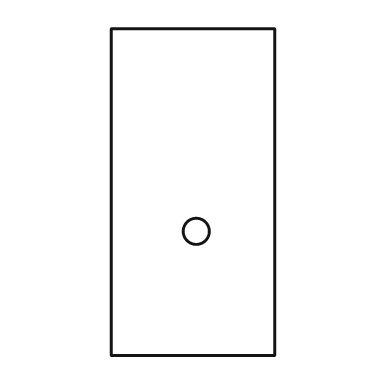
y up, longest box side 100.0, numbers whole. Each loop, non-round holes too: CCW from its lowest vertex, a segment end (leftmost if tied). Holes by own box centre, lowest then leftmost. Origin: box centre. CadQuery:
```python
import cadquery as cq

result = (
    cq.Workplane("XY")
    .moveTo(-25.0, -50.0)
    .lineTo(25.0, -50.0)
    .lineTo(25.0, 50.0)
    .lineTo(-25.0, 50.0)
    .close()
    .moveTo(1.0, -12.0)
    .circle(4.0)
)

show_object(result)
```